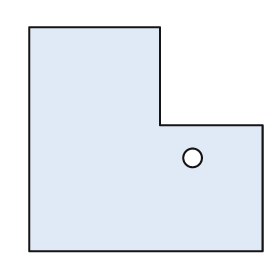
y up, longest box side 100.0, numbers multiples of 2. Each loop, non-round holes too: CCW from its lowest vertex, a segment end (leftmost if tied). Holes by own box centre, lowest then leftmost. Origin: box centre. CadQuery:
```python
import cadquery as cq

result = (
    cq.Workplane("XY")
    .moveTo(-50.0, -48.0)
    .lineTo(50.0, -48.0)
    .lineTo(50.0, 6.0)
    .lineTo(6.0, 6.0)
    .lineTo(6.0, 48.0)
    .lineTo(-50.0, 48.0)
    .close()
    .moveTo(20.0, -8.0)
    .circle(4.0)
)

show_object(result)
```